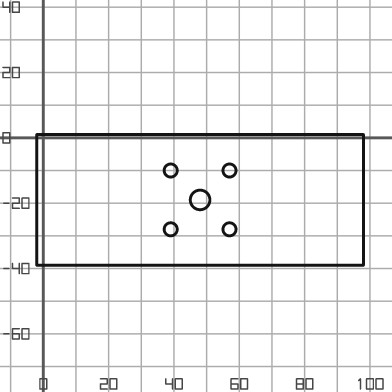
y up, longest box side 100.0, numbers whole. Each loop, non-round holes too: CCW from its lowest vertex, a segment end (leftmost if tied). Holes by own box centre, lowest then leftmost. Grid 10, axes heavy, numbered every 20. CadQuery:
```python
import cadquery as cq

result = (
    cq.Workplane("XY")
    .moveTo(-2.0, -39.0)
    .lineTo(98.0, -39.0)
    .lineTo(98.0, 1.0)
    .lineTo(-2.0, 1.0)
    .close()
    .moveTo(39.0, -28.0)
    .circle(2.0)
    .moveTo(57.0, -28.0)
    .circle(2.0)
    .moveTo(48.0, -19.0)
    .circle(3.0)
    .moveTo(39.0, -10.0)
    .circle(2.0)
    .moveTo(57.0, -10.0)
    .circle(2.0)
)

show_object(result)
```